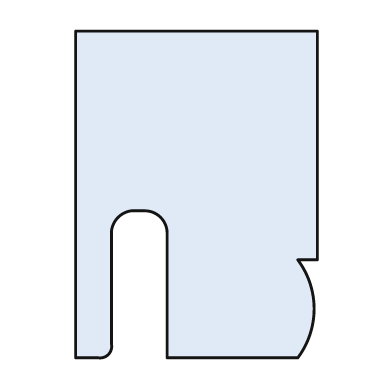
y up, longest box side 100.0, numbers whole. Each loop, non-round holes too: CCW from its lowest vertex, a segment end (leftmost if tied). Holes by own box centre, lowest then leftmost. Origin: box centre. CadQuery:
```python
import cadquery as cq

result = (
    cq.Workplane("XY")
    .moveTo(-37.0, -50.0)
    .lineTo(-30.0, -50.0)
    .threePointArc((-27.0, -49.0), (-26.0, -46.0))
    .lineTo(-26.0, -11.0)
    .threePointArc((-24.0, -7.0), (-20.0, -5.0))
    .lineTo(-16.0, -5.0)
    .threePointArc((-11.0, -7.0), (-9.0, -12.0))
    .lineTo(-9.0, -50.0)
    .lineTo(31.0, -50.0)
    .threePointArc((36.0, -35.0), (31.0, -20.0))
    .lineTo(37.0, -20.0)
    .lineTo(37.0, 50.0)
    .lineTo(-37.0, 50.0)
    .close()
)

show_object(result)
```